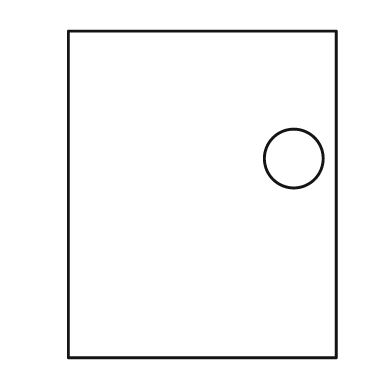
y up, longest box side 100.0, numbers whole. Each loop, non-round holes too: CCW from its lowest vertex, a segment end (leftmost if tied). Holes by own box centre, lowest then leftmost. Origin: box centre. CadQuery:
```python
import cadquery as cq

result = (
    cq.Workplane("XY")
    .moveTo(-41.0, -50.0)
    .lineTo(41.0, -50.0)
    .lineTo(41.0, 50.0)
    .lineTo(-41.0, 50.0)
    .close()
    .moveTo(28.0, 11.0)
    .circle(9.0)
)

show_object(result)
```